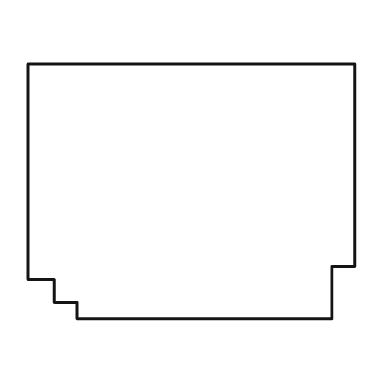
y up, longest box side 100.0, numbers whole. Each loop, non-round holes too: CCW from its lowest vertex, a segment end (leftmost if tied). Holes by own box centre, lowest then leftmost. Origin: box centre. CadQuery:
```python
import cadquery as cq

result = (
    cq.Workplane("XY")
    .moveTo(-35.0, -39.0)
    .lineTo(43.0, -39.0)
    .lineTo(43.0, -23.0)
    .lineTo(50.0, -23.0)
    .lineTo(50.0, 39.0)
    .lineTo(-50.0, 39.0)
    .lineTo(-50.0, -27.0)
    .lineTo(-42.0, -27.0)
    .lineTo(-42.0, -34.0)
    .lineTo(-35.0, -34.0)
    .close()
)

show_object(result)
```